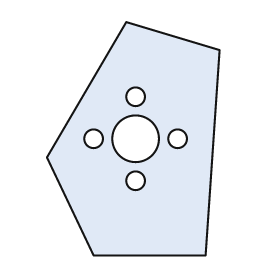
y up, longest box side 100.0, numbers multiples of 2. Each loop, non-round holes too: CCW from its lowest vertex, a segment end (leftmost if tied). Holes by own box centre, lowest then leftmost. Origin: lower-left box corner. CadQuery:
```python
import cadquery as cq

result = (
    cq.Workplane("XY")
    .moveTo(20.0, 0.0)
    .lineTo(68.0, 0.0)
    .lineTo(74.0, 88.0)
    .lineTo(34.0, 100.0)
    .lineTo(0.0, 42.0)
    .close()
    .moveTo(38.0, 32.0)
    .circle(4.0)
    .moveTo(20.0, 50.0)
    .circle(4.0)
    .moveTo(38.0, 50.0)
    .circle(10.0)
    .moveTo(56.0, 50.0)
    .circle(4.0)
    .moveTo(38.0, 68.0)
    .circle(4.0)
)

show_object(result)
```